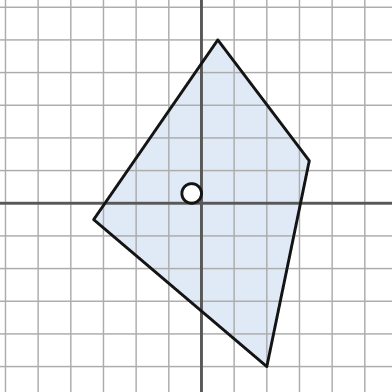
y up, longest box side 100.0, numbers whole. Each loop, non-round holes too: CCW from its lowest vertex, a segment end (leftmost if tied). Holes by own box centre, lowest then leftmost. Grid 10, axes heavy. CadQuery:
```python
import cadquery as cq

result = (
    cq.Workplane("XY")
    .moveTo(20.0, -50.0)
    .lineTo(33.0, 13.0)
    .lineTo(5.0, 50.0)
    .lineTo(-33.0, -5.0)
    .close()
    .moveTo(-3.0, 3.0)
    .circle(3.0)
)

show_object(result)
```